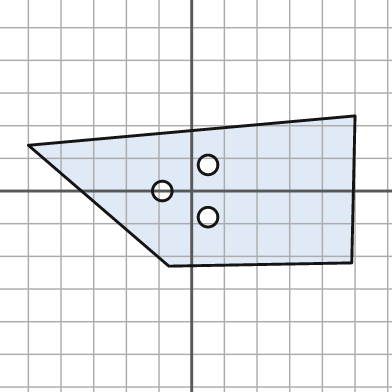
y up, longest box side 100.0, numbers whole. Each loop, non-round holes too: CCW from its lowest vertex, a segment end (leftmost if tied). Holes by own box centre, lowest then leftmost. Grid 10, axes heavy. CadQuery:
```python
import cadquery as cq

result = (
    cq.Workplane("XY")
    .moveTo(-7.0, -23.0)
    .lineTo(49.0, -22.0)
    .lineTo(50.0, 23.0)
    .lineTo(-50.0, 14.0)
    .close()
    .moveTo(5.0, -8.0)
    .circle(3.0)
    .moveTo(-9.0, 0.0)
    .circle(3.0)
    .moveTo(5.0, 8.0)
    .circle(3.0)
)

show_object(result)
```